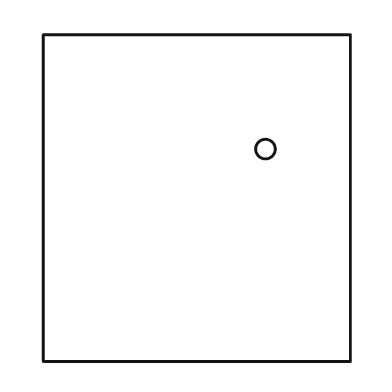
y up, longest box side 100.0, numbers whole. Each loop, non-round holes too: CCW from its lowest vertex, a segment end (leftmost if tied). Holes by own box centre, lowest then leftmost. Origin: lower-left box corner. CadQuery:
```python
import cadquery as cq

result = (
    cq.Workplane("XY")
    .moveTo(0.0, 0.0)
    .lineTo(94.0, 0.0)
    .lineTo(94.0, 100.0)
    .lineTo(0.0, 100.0)
    .close()
    .moveTo(68.0, 65.0)
    .circle(3.0)
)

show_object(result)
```